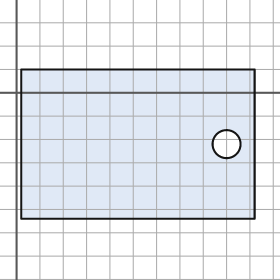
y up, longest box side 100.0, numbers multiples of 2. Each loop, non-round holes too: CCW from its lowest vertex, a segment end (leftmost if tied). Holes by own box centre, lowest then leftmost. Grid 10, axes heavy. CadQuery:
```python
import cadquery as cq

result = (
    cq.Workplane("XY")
    .moveTo(2.0, -54.0)
    .lineTo(102.0, -54.0)
    .lineTo(102.0, 10.0)
    .lineTo(2.0, 10.0)
    .close()
    .moveTo(90.0, -22.0)
    .circle(6.0)
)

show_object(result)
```